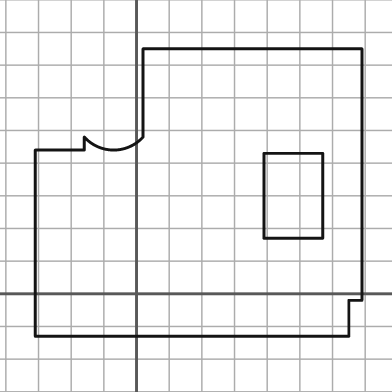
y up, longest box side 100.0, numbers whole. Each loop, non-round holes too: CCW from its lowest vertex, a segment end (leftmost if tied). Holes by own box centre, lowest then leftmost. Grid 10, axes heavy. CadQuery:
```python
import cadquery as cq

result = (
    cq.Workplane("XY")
    .moveTo(-31.0, -13.0)
    .lineTo(65.0, -13.0)
    .lineTo(65.0, -2.0)
    .lineTo(69.0, -2.0)
    .lineTo(69.0, 75.0)
    .lineTo(2.0, 75.0)
    .lineTo(2.0, 48.0)
    .threePointArc((-7.0, 44.0), (-16.0, 48.0))
    .lineTo(-16.0, 44.0)
    .lineTo(-31.0, 44.0)
    .close()
    .moveTo(39.0, 17.0)
    .lineTo(57.0, 17.0)
    .lineTo(57.0, 43.0)
    .lineTo(39.0, 43.0)
    .close()
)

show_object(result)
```